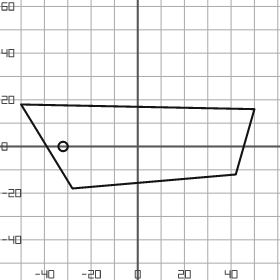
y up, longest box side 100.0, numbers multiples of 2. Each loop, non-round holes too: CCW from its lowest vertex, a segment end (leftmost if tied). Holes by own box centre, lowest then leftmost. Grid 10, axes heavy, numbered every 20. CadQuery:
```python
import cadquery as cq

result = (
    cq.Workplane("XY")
    .moveTo(-28.0, -18.0)
    .lineTo(42.0, -12.0)
    .lineTo(50.0, 16.0)
    .lineTo(-50.0, 18.0)
    .close()
    .moveTo(-32.0, 0.0)
    .circle(2.0)
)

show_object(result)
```